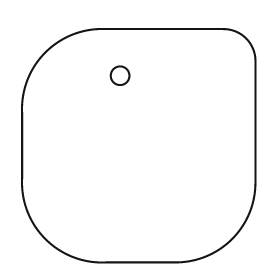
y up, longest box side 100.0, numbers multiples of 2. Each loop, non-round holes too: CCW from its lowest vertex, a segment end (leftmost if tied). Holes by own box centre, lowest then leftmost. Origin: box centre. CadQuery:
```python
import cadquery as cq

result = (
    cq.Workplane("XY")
    .moveTo(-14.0, -50.0)
    .lineTo(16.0, -50.0)
    .threePointArc((40.0, -40.0), (50.0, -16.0))
    .lineTo(50.0, 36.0)
    .threePointArc((46.0, 46.0), (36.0, 50.0))
    .lineTo(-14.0, 50.0)
    .threePointArc((-40.0, 40.0), (-50.0, 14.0))
    .lineTo(-50.0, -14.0)
    .threePointArc((-40.0, -40.0), (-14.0, -50.0))
    .close()
    .moveTo(-8.0, 30.0)
    .circle(4.0)
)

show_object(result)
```